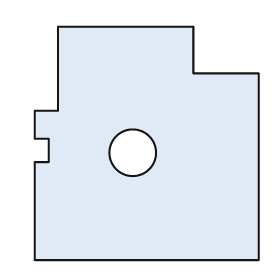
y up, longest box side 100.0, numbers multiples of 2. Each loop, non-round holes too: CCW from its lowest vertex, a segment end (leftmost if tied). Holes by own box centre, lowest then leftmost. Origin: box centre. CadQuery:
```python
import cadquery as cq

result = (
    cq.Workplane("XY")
    .moveTo(-48.0, -50.0)
    .lineTo(48.0, -50.0)
    .lineTo(48.0, 30.0)
    .lineTo(20.0, 30.0)
    .lineTo(20.0, 50.0)
    .lineTo(-38.0, 50.0)
    .lineTo(-38.0, 14.0)
    .lineTo(-48.0, 14.0)
    .lineTo(-48.0, 2.0)
    .lineTo(-42.0, 2.0)
    .lineTo(-42.0, -8.0)
    .lineTo(-48.0, -8.0)
    .close()
    .moveTo(-6.0, -4.0)
    .circle(10.0)
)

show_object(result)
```